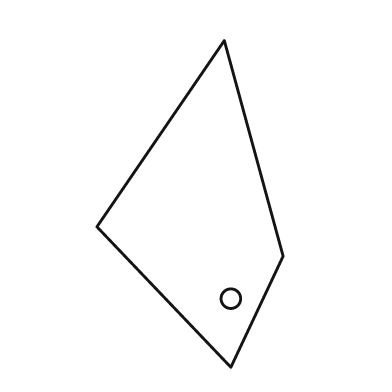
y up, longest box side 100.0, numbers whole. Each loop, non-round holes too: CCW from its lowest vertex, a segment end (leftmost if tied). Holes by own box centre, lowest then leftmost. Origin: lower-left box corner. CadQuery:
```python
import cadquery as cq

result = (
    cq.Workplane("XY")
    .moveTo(41.0, 0.0)
    .lineTo(57.0, 34.0)
    .lineTo(39.0, 100.0)
    .lineTo(0.0, 43.0)
    .close()
    .moveTo(41.0, 21.0)
    .circle(3.0)
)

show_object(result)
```